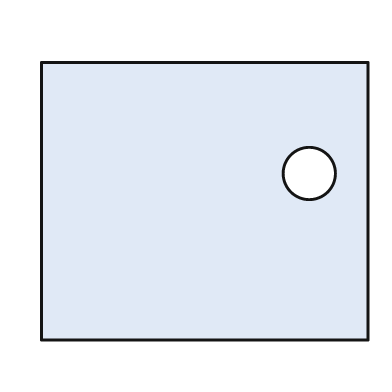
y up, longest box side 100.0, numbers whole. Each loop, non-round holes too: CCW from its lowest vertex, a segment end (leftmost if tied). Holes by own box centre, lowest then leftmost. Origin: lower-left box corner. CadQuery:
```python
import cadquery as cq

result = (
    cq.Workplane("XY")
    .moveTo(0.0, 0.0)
    .lineTo(100.0, 0.0)
    .lineTo(100.0, 85.0)
    .lineTo(0.0, 85.0)
    .close()
    .moveTo(82.0, 51.0)
    .circle(8.0)
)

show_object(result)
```